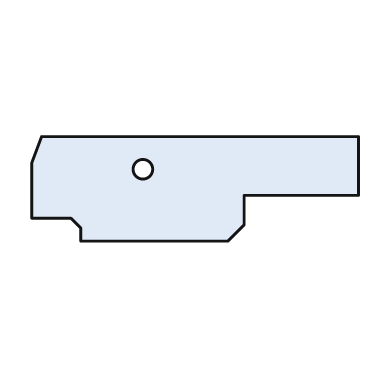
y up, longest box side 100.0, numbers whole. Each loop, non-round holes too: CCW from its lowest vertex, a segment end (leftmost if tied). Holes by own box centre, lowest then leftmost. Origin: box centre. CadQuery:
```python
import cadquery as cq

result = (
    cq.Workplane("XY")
    .moveTo(-35.0, -16.0)
    .lineTo(10.0, -16.0)
    .lineTo(15.0, -11.0)
    .lineTo(15.0, -2.0)
    .lineTo(50.0, -2.0)
    .lineTo(50.0, 16.0)
    .lineTo(-47.0, 16.0)
    .lineTo(-50.0, 8.0)
    .lineTo(-50.0, -9.0)
    .lineTo(-38.0, -9.0)
    .lineTo(-35.0, -12.0)
    .close()
    .moveTo(-16.0, 6.0)
    .circle(3.0)
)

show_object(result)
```